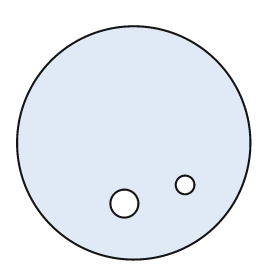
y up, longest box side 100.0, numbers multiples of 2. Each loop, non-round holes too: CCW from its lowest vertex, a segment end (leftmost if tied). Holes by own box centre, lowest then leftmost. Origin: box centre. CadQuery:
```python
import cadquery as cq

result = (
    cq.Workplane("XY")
    .moveTo(0.0, 0.0)
    .circle(50.0)
    .moveTo(-4.0, -26.0)
    .circle(6.0)
    .moveTo(22.0, -18.0)
    .circle(4.0)
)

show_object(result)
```